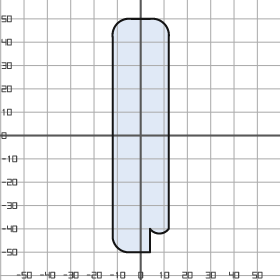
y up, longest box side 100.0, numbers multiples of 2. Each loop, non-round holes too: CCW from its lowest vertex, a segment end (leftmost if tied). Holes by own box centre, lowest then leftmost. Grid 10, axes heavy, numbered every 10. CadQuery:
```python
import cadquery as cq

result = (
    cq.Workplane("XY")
    .moveTo(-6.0, -50.0)
    .lineTo(4.0, -50.0)
    .lineTo(4.0, -40.0)
    .threePointArc((8.0, -42.0), (12.0, -40.0))
    .lineTo(12.0, 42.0)
    .threePointArc((10.0, 48.0), (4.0, 50.0))
    .lineTo(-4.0, 50.0)
    .threePointArc((-10.0, 48.0), (-12.0, 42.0))
    .lineTo(-12.0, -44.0)
    .threePointArc((-10.0, -48.0), (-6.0, -50.0))
    .close()
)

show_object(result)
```